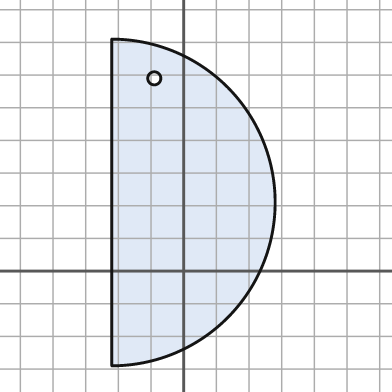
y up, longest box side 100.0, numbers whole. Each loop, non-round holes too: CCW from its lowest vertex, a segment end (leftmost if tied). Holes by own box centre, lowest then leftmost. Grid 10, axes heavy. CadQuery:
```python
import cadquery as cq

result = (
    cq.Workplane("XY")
    .moveTo(-22.0, -29.0)
    .threePointArc((28.0, 21.0), (-22.0, 71.0))
    .close()
    .moveTo(-9.0, 59.0)
    .circle(2.0)
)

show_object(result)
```